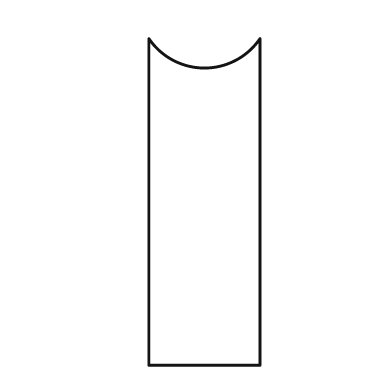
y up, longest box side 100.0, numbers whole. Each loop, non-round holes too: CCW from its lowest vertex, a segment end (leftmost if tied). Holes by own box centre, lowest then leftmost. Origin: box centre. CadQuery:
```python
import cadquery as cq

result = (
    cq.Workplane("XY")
    .moveTo(-17.0, -50.0)
    .lineTo(17.0, -50.0)
    .lineTo(17.0, 50.0)
    .threePointArc((0.0, 41.0), (-17.0, 50.0))
    .close()
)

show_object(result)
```